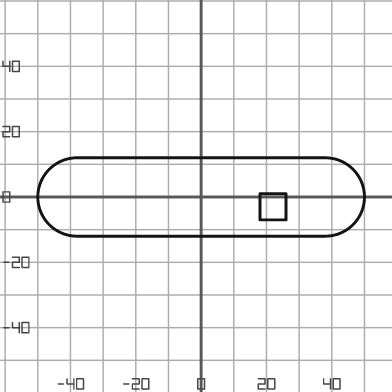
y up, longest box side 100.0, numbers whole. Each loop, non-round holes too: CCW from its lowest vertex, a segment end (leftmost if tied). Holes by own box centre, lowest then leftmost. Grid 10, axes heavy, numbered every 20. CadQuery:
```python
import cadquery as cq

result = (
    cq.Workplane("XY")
    .moveTo(-38.0, -12.0)
    .lineTo(38.0, -12.0)
    .threePointArc((50.0, 0.0), (38.0, 12.0))
    .lineTo(-38.0, 12.0)
    .threePointArc((-50.0, 0.0), (-38.0, -12.0))
    .close()
    .moveTo(18.0, -7.0)
    .lineTo(26.0, -7.0)
    .lineTo(26.0, 1.0)
    .lineTo(18.0, 1.0)
    .close()
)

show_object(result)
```